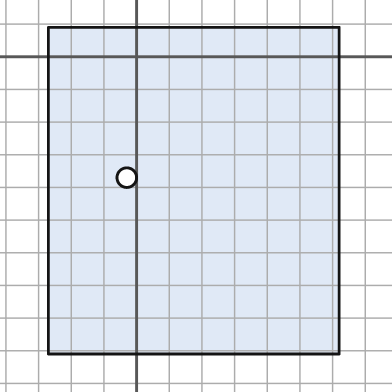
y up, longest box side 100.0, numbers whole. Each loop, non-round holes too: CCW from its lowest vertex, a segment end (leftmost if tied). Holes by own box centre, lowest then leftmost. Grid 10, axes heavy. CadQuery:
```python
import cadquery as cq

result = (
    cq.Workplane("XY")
    .moveTo(-27.0, -91.0)
    .lineTo(62.0, -91.0)
    .lineTo(62.0, 9.0)
    .lineTo(-27.0, 9.0)
    .close()
    .moveTo(-3.0, -37.0)
    .circle(3.0)
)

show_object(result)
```